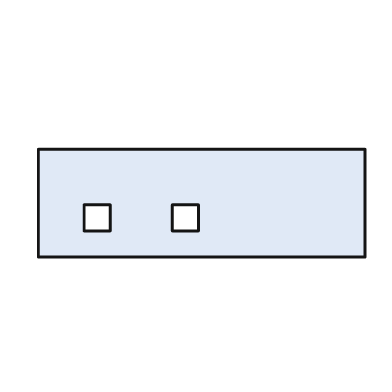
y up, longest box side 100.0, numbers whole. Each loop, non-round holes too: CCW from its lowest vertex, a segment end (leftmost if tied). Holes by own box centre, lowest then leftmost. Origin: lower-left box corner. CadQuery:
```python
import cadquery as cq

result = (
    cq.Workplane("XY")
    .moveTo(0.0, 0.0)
    .lineTo(100.0, 0.0)
    .lineTo(100.0, 33.0)
    .lineTo(0.0, 33.0)
    .close()
    .moveTo(14.0, 8.0)
    .lineTo(22.0, 8.0)
    .lineTo(22.0, 16.0)
    .lineTo(14.0, 16.0)
    .close()
    .moveTo(41.0, 8.0)
    .lineTo(49.0, 8.0)
    .lineTo(49.0, 16.0)
    .lineTo(41.0, 16.0)
    .close()
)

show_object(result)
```